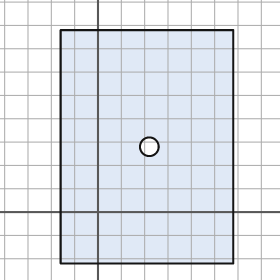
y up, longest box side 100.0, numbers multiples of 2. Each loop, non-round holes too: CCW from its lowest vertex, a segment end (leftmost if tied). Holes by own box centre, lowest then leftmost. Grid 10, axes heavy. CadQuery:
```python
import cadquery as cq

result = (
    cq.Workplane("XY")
    .moveTo(-16.0, -22.0)
    .lineTo(58.0, -22.0)
    .lineTo(58.0, 78.0)
    .lineTo(-16.0, 78.0)
    .close()
    .moveTo(22.0, 28.0)
    .circle(4.0)
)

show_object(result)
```